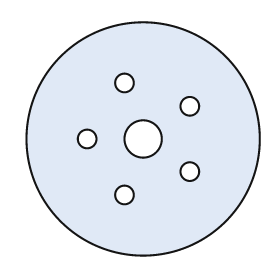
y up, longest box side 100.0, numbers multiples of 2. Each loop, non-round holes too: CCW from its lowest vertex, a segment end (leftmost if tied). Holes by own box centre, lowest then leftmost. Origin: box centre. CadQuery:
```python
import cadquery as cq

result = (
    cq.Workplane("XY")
    .moveTo(0.0, 0.0)
    .circle(50.0)
    .moveTo(-8.0, -24.0)
    .circle(4.0)
    .moveTo(20.0, -14.0)
    .circle(4.0)
    .moveTo(-24.0, 0.0)
    .circle(4.0)
    .moveTo(0.0, 0.0)
    .circle(8.0)
    .moveTo(20.0, 14.0)
    .circle(4.0)
    .moveTo(-8.0, 24.0)
    .circle(4.0)
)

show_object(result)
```